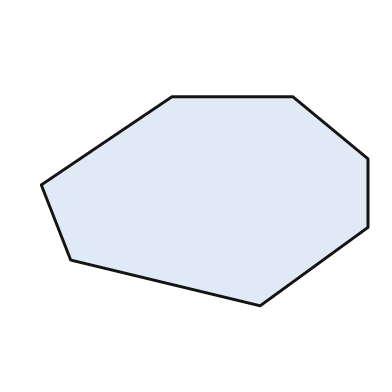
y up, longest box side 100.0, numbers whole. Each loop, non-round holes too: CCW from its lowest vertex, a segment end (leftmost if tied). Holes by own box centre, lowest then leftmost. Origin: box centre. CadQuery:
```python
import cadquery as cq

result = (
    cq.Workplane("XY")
    .moveTo(17.0, -32.0)
    .lineTo(50.0, -8.0)
    .lineTo(50.0, 13.0)
    .lineTo(27.0, 32.0)
    .lineTo(-10.0, 32.0)
    .lineTo(-50.0, 5.0)
    .lineTo(-41.0, -18.0)
    .close()
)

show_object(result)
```